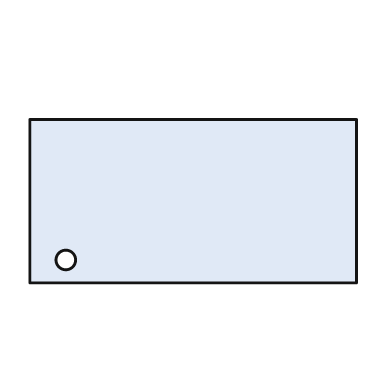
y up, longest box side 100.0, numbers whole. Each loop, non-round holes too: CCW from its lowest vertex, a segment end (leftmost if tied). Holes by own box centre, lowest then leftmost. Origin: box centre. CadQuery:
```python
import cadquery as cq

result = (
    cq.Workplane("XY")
    .moveTo(-50.0, -25.0)
    .lineTo(50.0, -25.0)
    .lineTo(50.0, 25.0)
    .lineTo(-50.0, 25.0)
    .close()
    .moveTo(-39.0, -18.0)
    .circle(3.0)
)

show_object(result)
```